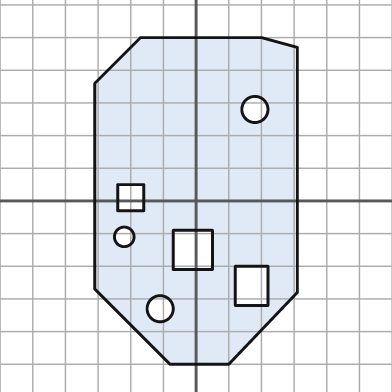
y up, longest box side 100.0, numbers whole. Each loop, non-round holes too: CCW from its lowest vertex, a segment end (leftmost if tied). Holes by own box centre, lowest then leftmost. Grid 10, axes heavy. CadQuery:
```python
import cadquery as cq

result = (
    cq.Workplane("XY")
    .moveTo(-8.0, -50.0)
    .lineTo(10.0, -50.0)
    .lineTo(31.0, -28.0)
    .lineTo(31.0, 47.0)
    .lineTo(20.0, 50.0)
    .lineTo(-17.0, 50.0)
    .lineTo(-31.0, 36.0)
    .lineTo(-31.0, -27.0)
    .close()
    .moveTo(-11.0, -33.0)
    .circle(4.0)
    .moveTo(12.0, -32.0)
    .lineTo(22.0, -32.0)
    .lineTo(22.0, -20.0)
    .lineTo(12.0, -20.0)
    .close()
    .moveTo(-7.0, -21.0)
    .lineTo(5.0, -21.0)
    .lineTo(5.0, -9.0)
    .lineTo(-7.0, -9.0)
    .close()
    .moveTo(-22.0, -11.0)
    .circle(3.0)
    .moveTo(-24.0, -3.0)
    .lineTo(-16.0, -3.0)
    .lineTo(-16.0, 5.0)
    .lineTo(-24.0, 5.0)
    .close()
    .moveTo(18.0, 28.0)
    .circle(4.0)
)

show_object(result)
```